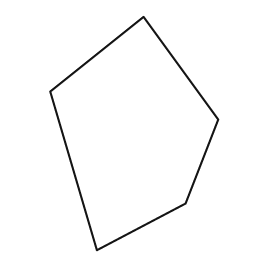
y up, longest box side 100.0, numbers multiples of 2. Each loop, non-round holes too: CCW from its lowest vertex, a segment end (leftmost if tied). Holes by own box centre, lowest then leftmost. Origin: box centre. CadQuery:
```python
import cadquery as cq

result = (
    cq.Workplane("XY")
    .moveTo(-16.0, -50.0)
    .lineTo(22.0, -30.0)
    .lineTo(36.0, 6.0)
    .lineTo(4.0, 50.0)
    .lineTo(-36.0, 18.0)
    .close()
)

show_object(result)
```